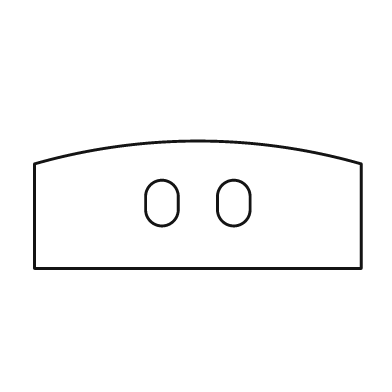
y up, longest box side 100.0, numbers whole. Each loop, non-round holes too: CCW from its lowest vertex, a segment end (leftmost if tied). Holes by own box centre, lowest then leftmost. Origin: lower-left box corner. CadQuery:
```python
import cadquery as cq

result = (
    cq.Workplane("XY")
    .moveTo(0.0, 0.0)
    .lineTo(100.0, 0.0)
    .lineTo(100.0, 32.0)
    .threePointArc((50.0, 39.0), (0.0, 32.0))
    .close()
    .moveTo(34.0, 18.0)
    .threePointArc((39.0, 13.0), (44.0, 18.0))
    .lineTo(44.0, 22.0)
    .threePointArc((39.0, 27.0), (34.0, 22.0))
    .close()
    .moveTo(56.0, 18.0)
    .threePointArc((61.0, 13.0), (66.0, 18.0))
    .lineTo(66.0, 22.0)
    .threePointArc((61.0, 27.0), (56.0, 22.0))
    .close()
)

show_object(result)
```